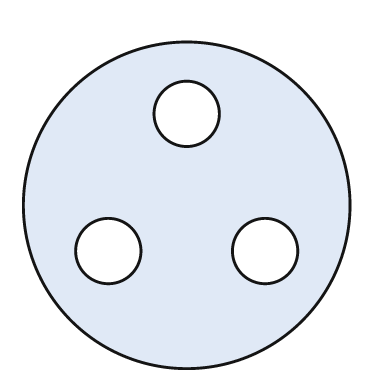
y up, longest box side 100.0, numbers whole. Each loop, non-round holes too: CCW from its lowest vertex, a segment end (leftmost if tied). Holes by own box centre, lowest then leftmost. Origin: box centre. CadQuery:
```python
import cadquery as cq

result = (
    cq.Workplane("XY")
    .moveTo(0.0, 0.0)
    .circle(50.0)
    .moveTo(-24.0, -14.0)
    .circle(10.0)
    .moveTo(24.0, -14.0)
    .circle(10.0)
    .moveTo(0.0, 28.0)
    .circle(10.0)
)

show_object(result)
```